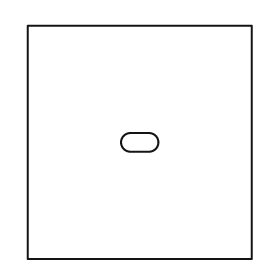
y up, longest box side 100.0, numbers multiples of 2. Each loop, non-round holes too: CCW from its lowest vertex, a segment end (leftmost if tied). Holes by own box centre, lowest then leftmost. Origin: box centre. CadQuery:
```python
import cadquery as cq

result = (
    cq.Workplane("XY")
    .moveTo(-48.0, -50.0)
    .lineTo(48.0, -50.0)
    .lineTo(48.0, 50.0)
    .lineTo(-48.0, 50.0)
    .close()
    .moveTo(-4.0, -4.0)
    .lineTo(4.0, -4.0)
    .threePointArc((8.0, 0.0), (4.0, 4.0))
    .lineTo(-4.0, 4.0)
    .threePointArc((-8.0, 0.0), (-4.0, -4.0))
    .close()
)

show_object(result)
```